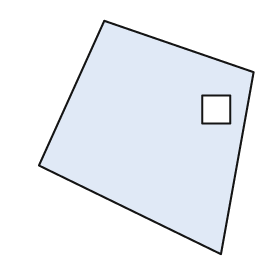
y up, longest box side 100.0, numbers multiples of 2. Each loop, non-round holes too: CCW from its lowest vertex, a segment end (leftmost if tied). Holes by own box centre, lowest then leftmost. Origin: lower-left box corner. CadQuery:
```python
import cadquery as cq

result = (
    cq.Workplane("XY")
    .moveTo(78.0, 0.0)
    .lineTo(92.0, 78.0)
    .lineTo(28.0, 100.0)
    .lineTo(0.0, 38.0)
    .close()
    .moveTo(70.0, 56.0)
    .lineTo(82.0, 56.0)
    .lineTo(82.0, 68.0)
    .lineTo(70.0, 68.0)
    .close()
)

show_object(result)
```